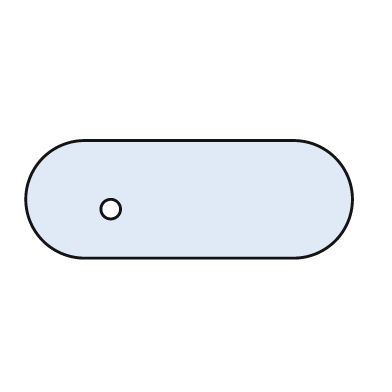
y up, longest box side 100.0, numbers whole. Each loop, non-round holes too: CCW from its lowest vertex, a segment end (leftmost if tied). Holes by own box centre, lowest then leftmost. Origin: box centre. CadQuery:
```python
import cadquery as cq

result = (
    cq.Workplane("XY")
    .moveTo(-32.0, -18.0)
    .lineTo(32.0, -18.0)
    .threePointArc((50.0, 0.0), (32.0, 18.0))
    .lineTo(-32.0, 18.0)
    .threePointArc((-50.0, 0.0), (-32.0, -18.0))
    .close()
    .moveTo(-24.0, -3.0)
    .circle(3.0)
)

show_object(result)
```